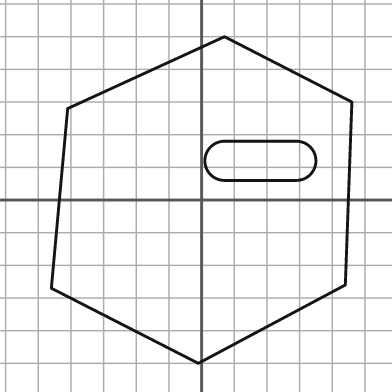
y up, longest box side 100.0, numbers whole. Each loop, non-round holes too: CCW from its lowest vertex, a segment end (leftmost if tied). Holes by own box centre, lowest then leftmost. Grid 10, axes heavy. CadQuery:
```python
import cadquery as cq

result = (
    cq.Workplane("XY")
    .moveTo(-1.0, -50.0)
    .lineTo(44.0, -26.0)
    .lineTo(46.0, 30.0)
    .lineTo(7.0, 50.0)
    .lineTo(-41.0, 28.0)
    .lineTo(-46.0, -27.0)
    .close()
    .moveTo(7.0, 6.0)
    .lineTo(29.0, 6.0)
    .threePointArc((35.0, 12.0), (29.0, 18.0))
    .lineTo(7.0, 18.0)
    .threePointArc((1.0, 12.0), (7.0, 6.0))
    .close()
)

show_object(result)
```